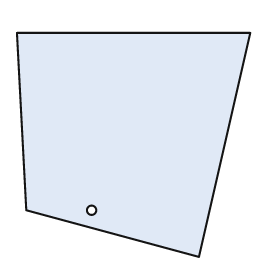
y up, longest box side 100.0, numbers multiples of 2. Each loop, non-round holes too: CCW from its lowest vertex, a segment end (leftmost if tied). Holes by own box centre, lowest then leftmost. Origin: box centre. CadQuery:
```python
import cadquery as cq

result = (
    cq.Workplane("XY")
    .moveTo(28.0, -48.0)
    .lineTo(50.0, 48.0)
    .lineTo(-50.0, 48.0)
    .lineTo(-46.0, -28.0)
    .close()
    .moveTo(-18.0, -28.0)
    .circle(2.0)
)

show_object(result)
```